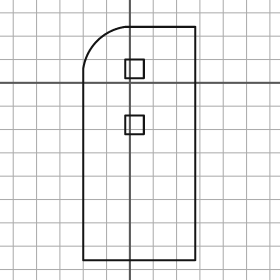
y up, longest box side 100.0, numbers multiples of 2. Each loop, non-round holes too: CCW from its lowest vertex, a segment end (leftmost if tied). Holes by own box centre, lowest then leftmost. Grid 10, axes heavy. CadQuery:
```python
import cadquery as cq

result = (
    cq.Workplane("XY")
    .moveTo(-20.0, -76.0)
    .lineTo(28.0, -76.0)
    .lineTo(28.0, 24.0)
    .lineTo(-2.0, 24.0)
    .threePointArc((-14.0, 18.0), (-20.0, 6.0))
    .close()
    .moveTo(-2.0, -22.0)
    .lineTo(6.0, -22.0)
    .lineTo(6.0, -14.0)
    .lineTo(-2.0, -14.0)
    .close()
    .moveTo(-2.0, 2.0)
    .lineTo(6.0, 2.0)
    .lineTo(6.0, 10.0)
    .lineTo(-2.0, 10.0)
    .close()
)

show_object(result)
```